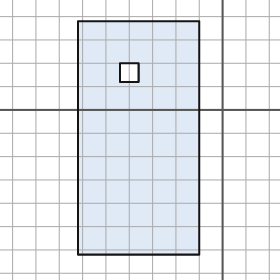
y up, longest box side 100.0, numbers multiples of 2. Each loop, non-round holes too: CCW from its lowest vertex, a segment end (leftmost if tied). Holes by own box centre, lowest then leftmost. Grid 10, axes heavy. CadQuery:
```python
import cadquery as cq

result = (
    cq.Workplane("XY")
    .moveTo(-62.0, -62.0)
    .lineTo(-10.0, -62.0)
    .lineTo(-10.0, 38.0)
    .lineTo(-62.0, 38.0)
    .close()
    .moveTo(-44.0, 12.0)
    .lineTo(-36.0, 12.0)
    .lineTo(-36.0, 20.0)
    .lineTo(-44.0, 20.0)
    .close()
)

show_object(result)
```